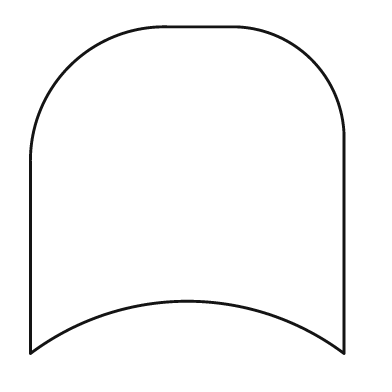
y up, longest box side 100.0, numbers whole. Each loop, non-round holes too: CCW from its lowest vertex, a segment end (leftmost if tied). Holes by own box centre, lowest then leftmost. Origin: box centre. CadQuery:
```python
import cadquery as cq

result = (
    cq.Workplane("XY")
    .moveTo(-48.0, -50.0)
    .threePointArc((0.0, -34.0), (48.0, -50.0))
    .lineTo(48.0, 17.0)
    .threePointArc((38.0, 40.0), (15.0, 50.0))
    .lineTo(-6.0, 50.0)
    .threePointArc((-36.0, 38.0), (-48.0, 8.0))
    .close()
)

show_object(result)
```